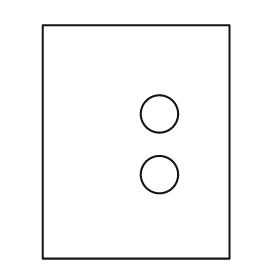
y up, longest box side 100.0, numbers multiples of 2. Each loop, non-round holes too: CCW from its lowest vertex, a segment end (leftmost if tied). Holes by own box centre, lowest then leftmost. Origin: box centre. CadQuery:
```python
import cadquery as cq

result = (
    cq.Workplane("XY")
    .moveTo(-40.0, -50.0)
    .lineTo(40.0, -50.0)
    .lineTo(40.0, 50.0)
    .lineTo(-40.0, 50.0)
    .close()
    .moveTo(10.0, -14.0)
    .circle(8.0)
    .moveTo(10.0, 12.0)
    .circle(8.0)
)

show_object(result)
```